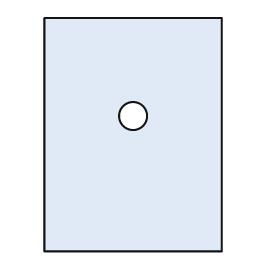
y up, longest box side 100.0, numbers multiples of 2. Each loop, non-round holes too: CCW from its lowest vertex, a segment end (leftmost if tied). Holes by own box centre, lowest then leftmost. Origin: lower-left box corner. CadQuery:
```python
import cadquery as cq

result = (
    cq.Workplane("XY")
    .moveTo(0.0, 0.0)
    .lineTo(76.0, 0.0)
    .lineTo(76.0, 100.0)
    .lineTo(0.0, 100.0)
    .close()
    .moveTo(38.0, 58.0)
    .circle(6.0)
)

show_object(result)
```